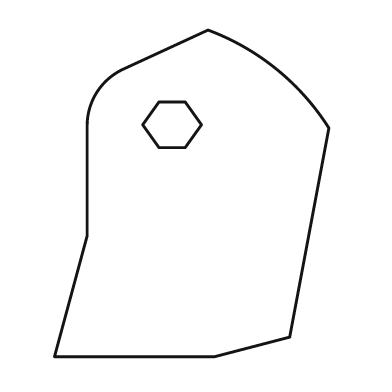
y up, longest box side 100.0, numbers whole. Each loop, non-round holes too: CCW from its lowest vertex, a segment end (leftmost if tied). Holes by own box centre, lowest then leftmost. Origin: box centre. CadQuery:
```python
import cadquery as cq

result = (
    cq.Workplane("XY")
    .moveTo(-42.0, -50.0)
    .lineTo(7.0, -50.0)
    .lineTo(30.0, -44.0)
    .lineTo(42.0, 20.0)
    .threePointArc((26.0, 38.0), (5.0, 50.0))
    .lineTo(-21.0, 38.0)
    .threePointArc((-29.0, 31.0), (-32.0, 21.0))
    .lineTo(-32.0, -13.0)
    .close()
    .moveTo(-10.0, 14.0)
    .lineTo(-2.0, 14.0)
    .lineTo(3.0, 21.0)
    .lineTo(-2.0, 28.0)
    .lineTo(-10.0, 28.0)
    .lineTo(-15.0, 21.0)
    .close()
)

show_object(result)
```